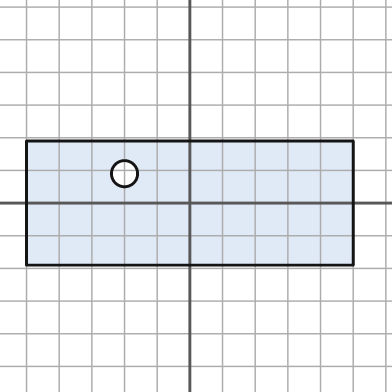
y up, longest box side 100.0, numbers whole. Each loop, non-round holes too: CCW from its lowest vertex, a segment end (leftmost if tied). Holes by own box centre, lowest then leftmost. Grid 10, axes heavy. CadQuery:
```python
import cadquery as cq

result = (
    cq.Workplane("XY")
    .moveTo(-50.0, -19.0)
    .lineTo(50.0, -19.0)
    .lineTo(50.0, 19.0)
    .lineTo(-50.0, 19.0)
    .close()
    .moveTo(-20.0, 9.0)
    .circle(4.0)
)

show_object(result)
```